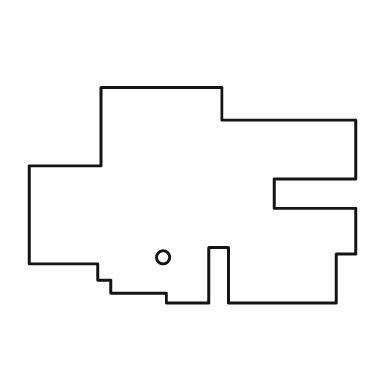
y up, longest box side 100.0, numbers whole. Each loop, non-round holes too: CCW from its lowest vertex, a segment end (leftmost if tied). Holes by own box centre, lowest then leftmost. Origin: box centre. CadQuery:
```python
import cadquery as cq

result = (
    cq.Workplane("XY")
    .moveTo(-8.0, -33.0)
    .lineTo(5.0, -33.0)
    .lineTo(5.0, -16.0)
    .lineTo(11.0, -16.0)
    .lineTo(11.0, -33.0)
    .lineTo(44.0, -33.0)
    .lineTo(44.0, -18.0)
    .lineTo(50.0, -18.0)
    .lineTo(50.0, -4.0)
    .lineTo(25.0, -4.0)
    .lineTo(25.0, 5.0)
    .lineTo(50.0, 5.0)
    .lineTo(50.0, 23.0)
    .lineTo(9.0, 23.0)
    .lineTo(9.0, 33.0)
    .lineTo(-28.0, 33.0)
    .lineTo(-28.0, 9.0)
    .lineTo(-50.0, 9.0)
    .lineTo(-50.0, -21.0)
    .lineTo(-29.0, -21.0)
    .lineTo(-29.0, -26.0)
    .lineTo(-25.0, -26.0)
    .lineTo(-25.0, -30.0)
    .lineTo(-8.0, -30.0)
    .close()
    .moveTo(-9.0, -19.0)
    .circle(2.0)
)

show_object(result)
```